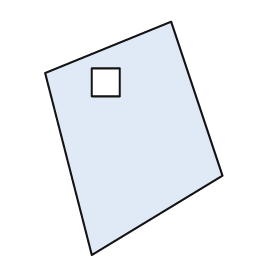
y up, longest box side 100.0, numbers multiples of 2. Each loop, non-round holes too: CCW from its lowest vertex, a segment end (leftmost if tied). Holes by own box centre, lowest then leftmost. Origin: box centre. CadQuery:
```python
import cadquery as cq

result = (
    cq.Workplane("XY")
    .moveTo(-18.0, -50.0)
    .lineTo(38.0, -16.0)
    .lineTo(16.0, 50.0)
    .lineTo(-38.0, 28.0)
    .close()
    .moveTo(-18.0, 18.0)
    .lineTo(-6.0, 18.0)
    .lineTo(-6.0, 30.0)
    .lineTo(-18.0, 30.0)
    .close()
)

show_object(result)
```